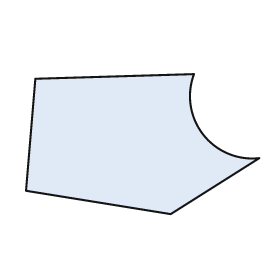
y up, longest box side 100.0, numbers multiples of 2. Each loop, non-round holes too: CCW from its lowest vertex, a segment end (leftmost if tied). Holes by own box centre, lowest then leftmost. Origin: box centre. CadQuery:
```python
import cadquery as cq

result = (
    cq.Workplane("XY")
    .moveTo(12.0, -30.0)
    .lineTo(50.0, -6.0)
    .threePointArc((26.0, 4.0), (22.0, 30.0))
    .lineTo(-46.0, 28.0)
    .lineTo(-50.0, -20.0)
    .close()
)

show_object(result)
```